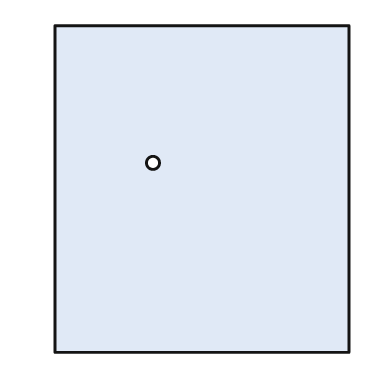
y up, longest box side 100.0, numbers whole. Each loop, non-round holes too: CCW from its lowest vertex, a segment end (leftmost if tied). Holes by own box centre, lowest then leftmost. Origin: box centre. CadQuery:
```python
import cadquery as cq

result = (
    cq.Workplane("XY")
    .moveTo(-45.0, -50.0)
    .lineTo(45.0, -50.0)
    .lineTo(45.0, 50.0)
    .lineTo(-45.0, 50.0)
    .close()
    .moveTo(-15.0, 8.0)
    .circle(2.0)
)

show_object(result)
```